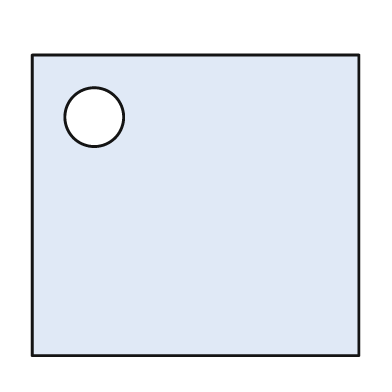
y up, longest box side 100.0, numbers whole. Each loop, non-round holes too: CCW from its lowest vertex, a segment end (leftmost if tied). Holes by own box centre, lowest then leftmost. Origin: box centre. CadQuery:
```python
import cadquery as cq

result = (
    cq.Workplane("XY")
    .moveTo(-50.0, -46.0)
    .lineTo(50.0, -46.0)
    .lineTo(50.0, 46.0)
    .lineTo(-50.0, 46.0)
    .close()
    .moveTo(-31.0, 27.0)
    .circle(9.0)
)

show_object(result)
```